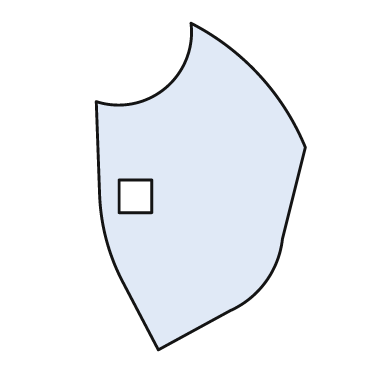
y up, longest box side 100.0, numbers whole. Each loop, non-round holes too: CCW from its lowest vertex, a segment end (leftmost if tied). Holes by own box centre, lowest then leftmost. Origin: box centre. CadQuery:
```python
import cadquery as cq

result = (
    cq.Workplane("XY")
    .moveTo(-13.0, -50.0)
    .lineTo(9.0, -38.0)
    .threePointArc((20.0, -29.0), (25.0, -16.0))
    .lineTo(32.0, 12.0)
    .threePointArc((18.0, 34.0), (-3.0, 50.0))
    .threePointArc((-11.0, 30.0), (-32.0, 26.0))
    .lineTo(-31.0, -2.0)
    .threePointArc((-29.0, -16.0), (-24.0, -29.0))
    .close()
    .moveTo(-25.0, -8.0)
    .lineTo(-15.0, -8.0)
    .lineTo(-15.0, 2.0)
    .lineTo(-25.0, 2.0)
    .close()
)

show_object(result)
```